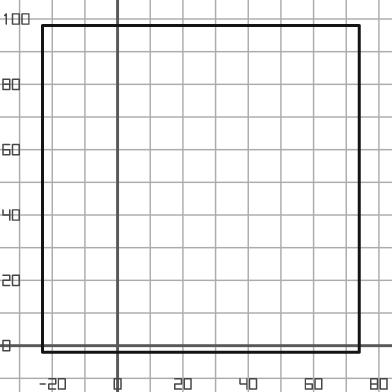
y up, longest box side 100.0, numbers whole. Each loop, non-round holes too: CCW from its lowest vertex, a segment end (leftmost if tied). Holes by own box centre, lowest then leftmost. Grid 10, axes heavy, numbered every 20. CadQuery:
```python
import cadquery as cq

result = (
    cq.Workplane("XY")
    .moveTo(-23.0, -2.0)
    .lineTo(74.0, -2.0)
    .lineTo(74.0, 98.0)
    .lineTo(-23.0, 98.0)
    .close()
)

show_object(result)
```